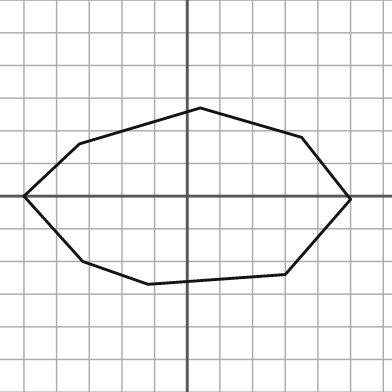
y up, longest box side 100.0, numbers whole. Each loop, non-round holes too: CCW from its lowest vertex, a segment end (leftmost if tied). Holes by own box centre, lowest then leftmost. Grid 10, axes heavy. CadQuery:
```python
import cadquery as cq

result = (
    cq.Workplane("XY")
    .moveTo(-12.0, -27.0)
    .lineTo(30.0, -24.0)
    .lineTo(50.0, -1.0)
    .lineTo(35.0, 18.0)
    .lineTo(4.0, 27.0)
    .lineTo(-33.0, 16.0)
    .lineTo(-50.0, 0.0)
    .lineTo(-32.0, -20.0)
    .close()
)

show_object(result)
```